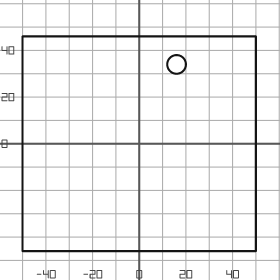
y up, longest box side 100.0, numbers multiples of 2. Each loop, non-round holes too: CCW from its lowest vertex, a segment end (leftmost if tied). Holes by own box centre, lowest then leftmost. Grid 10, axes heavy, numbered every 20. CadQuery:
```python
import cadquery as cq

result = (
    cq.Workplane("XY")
    .moveTo(-50.0, -46.0)
    .lineTo(50.0, -46.0)
    .lineTo(50.0, 46.0)
    .lineTo(-50.0, 46.0)
    .close()
    .moveTo(16.0, 34.0)
    .circle(4.0)
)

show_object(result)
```